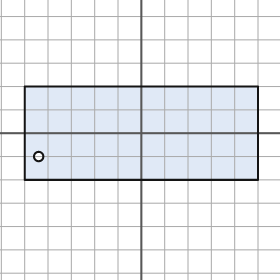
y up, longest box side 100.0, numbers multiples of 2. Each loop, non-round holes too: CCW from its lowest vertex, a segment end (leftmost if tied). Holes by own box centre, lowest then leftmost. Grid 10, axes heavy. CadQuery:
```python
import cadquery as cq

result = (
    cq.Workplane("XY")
    .moveTo(-50.0, -20.0)
    .lineTo(50.0, -20.0)
    .lineTo(50.0, 20.0)
    .lineTo(-50.0, 20.0)
    .close()
    .moveTo(-44.0, -10.0)
    .circle(2.0)
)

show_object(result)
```